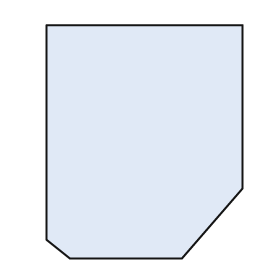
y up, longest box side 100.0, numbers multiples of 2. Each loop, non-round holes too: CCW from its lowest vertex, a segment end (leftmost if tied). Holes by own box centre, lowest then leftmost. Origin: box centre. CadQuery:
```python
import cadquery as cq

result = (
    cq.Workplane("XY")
    .moveTo(-32.0, -50.0)
    .lineTo(16.0, -50.0)
    .lineTo(42.0, -20.0)
    .lineTo(42.0, 50.0)
    .lineTo(-42.0, 50.0)
    .lineTo(-42.0, -42.0)
    .close()
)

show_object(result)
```